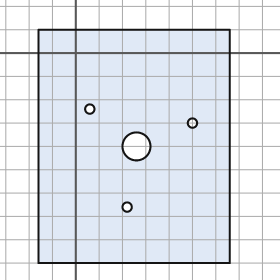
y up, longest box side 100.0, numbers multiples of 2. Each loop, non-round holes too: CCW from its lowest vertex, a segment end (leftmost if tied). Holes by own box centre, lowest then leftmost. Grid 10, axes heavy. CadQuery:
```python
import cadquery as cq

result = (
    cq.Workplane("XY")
    .moveTo(-16.0, -90.0)
    .lineTo(66.0, -90.0)
    .lineTo(66.0, 10.0)
    .lineTo(-16.0, 10.0)
    .close()
    .moveTo(22.0, -66.0)
    .circle(2.0)
    .moveTo(26.0, -40.0)
    .circle(6.0)
    .moveTo(50.0, -30.0)
    .circle(2.0)
    .moveTo(6.0, -24.0)
    .circle(2.0)
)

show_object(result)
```